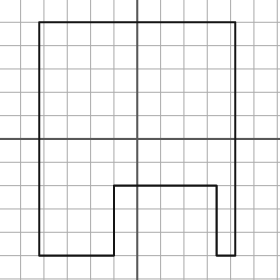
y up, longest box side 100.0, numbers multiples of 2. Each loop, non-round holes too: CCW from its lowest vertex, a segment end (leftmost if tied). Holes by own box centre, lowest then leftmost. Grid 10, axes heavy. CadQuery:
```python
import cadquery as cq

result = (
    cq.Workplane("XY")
    .moveTo(-42.0, -50.0)
    .lineTo(-10.0, -50.0)
    .lineTo(-10.0, -20.0)
    .lineTo(34.0, -20.0)
    .lineTo(34.0, -50.0)
    .lineTo(42.0, -50.0)
    .lineTo(42.0, 50.0)
    .lineTo(-42.0, 50.0)
    .close()
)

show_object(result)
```